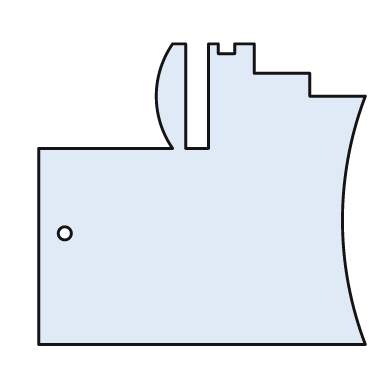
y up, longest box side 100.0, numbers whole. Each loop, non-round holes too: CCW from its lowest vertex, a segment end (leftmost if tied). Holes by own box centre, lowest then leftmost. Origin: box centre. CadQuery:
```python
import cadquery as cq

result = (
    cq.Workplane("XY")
    .moveTo(-50.0, -46.0)
    .lineTo(50.0, -46.0)
    .threePointArc((43.0, -8.0), (50.0, 30.0))
    .lineTo(33.0, 30.0)
    .lineTo(33.0, 37.0)
    .lineTo(16.0, 37.0)
    .lineTo(16.0, 46.0)
    .lineTo(10.0, 46.0)
    .lineTo(10.0, 43.0)
    .lineTo(5.0, 43.0)
    .lineTo(5.0, 46.0)
    .lineTo(2.0, 46.0)
    .lineTo(2.0, 14.0)
    .lineTo(-5.0, 14.0)
    .lineTo(-5.0, 46.0)
    .lineTo(-9.0, 46.0)
    .threePointArc((-14.0, 30.0), (-9.0, 14.0))
    .lineTo(-50.0, 14.0)
    .close()
    .moveTo(-42.0, -12.0)
    .circle(2.0)
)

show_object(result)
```